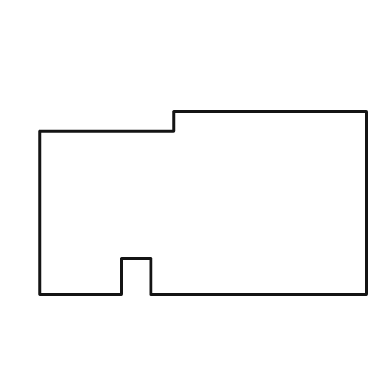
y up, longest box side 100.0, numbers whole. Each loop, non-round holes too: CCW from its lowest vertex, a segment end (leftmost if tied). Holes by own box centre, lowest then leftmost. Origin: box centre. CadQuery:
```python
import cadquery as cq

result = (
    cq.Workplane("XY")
    .moveTo(-50.0, -28.0)
    .lineTo(-25.0, -28.0)
    .lineTo(-25.0, -17.0)
    .lineTo(-16.0, -17.0)
    .lineTo(-16.0, -28.0)
    .lineTo(50.0, -28.0)
    .lineTo(50.0, 28.0)
    .lineTo(-9.0, 28.0)
    .lineTo(-9.0, 22.0)
    .lineTo(-50.0, 22.0)
    .close()
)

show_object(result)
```